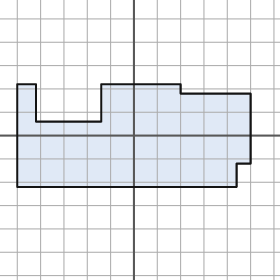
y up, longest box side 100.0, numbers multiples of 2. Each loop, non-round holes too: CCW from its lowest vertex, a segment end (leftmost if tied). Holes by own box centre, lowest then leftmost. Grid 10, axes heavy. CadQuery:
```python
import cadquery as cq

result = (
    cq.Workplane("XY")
    .moveTo(-50.0, -22.0)
    .lineTo(44.0, -22.0)
    .lineTo(44.0, -12.0)
    .lineTo(50.0, -12.0)
    .lineTo(50.0, 18.0)
    .lineTo(20.0, 18.0)
    .lineTo(20.0, 22.0)
    .lineTo(-14.0, 22.0)
    .lineTo(-14.0, 6.0)
    .lineTo(-42.0, 6.0)
    .lineTo(-42.0, 22.0)
    .lineTo(-50.0, 22.0)
    .close()
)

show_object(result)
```